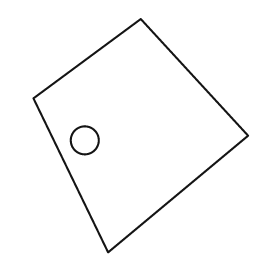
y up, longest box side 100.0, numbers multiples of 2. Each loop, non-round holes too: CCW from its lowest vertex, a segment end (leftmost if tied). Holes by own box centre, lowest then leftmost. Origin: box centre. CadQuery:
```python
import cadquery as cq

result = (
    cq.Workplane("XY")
    .moveTo(-14.0, -50.0)
    .lineTo(46.0, 0.0)
    .lineTo(0.0, 50.0)
    .lineTo(-46.0, 16.0)
    .close()
    .moveTo(-24.0, -2.0)
    .circle(6.0)
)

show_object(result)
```